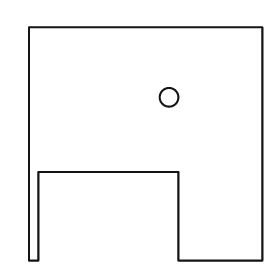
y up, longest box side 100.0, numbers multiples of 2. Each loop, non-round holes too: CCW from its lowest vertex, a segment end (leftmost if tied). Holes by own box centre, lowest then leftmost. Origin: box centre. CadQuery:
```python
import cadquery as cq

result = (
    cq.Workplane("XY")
    .moveTo(-50.0, -50.0)
    .lineTo(-46.0, -50.0)
    .lineTo(-46.0, -12.0)
    .lineTo(14.0, -12.0)
    .lineTo(14.0, -50.0)
    .lineTo(50.0, -50.0)
    .lineTo(50.0, 50.0)
    .lineTo(-50.0, 50.0)
    .close()
    .moveTo(10.0, 20.0)
    .circle(4.0)
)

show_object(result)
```